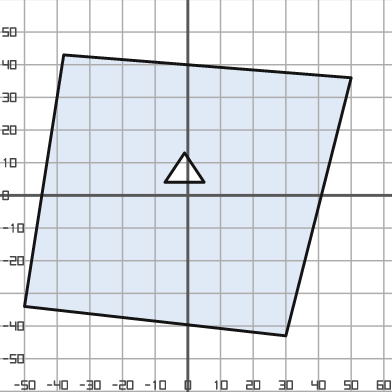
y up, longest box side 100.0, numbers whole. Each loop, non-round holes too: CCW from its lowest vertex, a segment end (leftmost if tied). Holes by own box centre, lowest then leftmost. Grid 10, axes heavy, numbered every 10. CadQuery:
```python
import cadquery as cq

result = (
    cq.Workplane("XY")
    .moveTo(30.0, -43.0)
    .lineTo(50.0, 36.0)
    .lineTo(-38.0, 43.0)
    .lineTo(-50.0, -34.0)
    .close()
    .moveTo(-7.0, 4.0)
    .lineTo(5.0, 4.0)
    .lineTo(-1.0, 13.0)
    .close()
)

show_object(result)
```